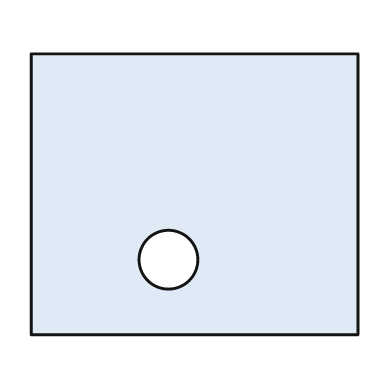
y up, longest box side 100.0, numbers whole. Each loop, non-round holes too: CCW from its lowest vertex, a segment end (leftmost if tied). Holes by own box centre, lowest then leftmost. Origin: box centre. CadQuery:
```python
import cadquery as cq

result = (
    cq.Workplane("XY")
    .moveTo(-50.0, -43.0)
    .lineTo(50.0, -43.0)
    .lineTo(50.0, 43.0)
    .lineTo(-50.0, 43.0)
    .close()
    .moveTo(-8.0, -20.0)
    .circle(9.0)
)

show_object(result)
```